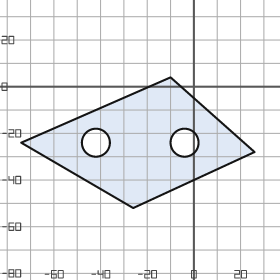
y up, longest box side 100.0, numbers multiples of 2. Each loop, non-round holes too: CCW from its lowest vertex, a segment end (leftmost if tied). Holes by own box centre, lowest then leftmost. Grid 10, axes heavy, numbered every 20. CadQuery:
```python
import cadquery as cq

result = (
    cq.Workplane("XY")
    .moveTo(-26.0, -52.0)
    .lineTo(26.0, -28.0)
    .lineTo(-10.0, 4.0)
    .lineTo(-74.0, -24.0)
    .close()
    .moveTo(-42.0, -24.0)
    .circle(6.0)
    .moveTo(-4.0, -24.0)
    .circle(6.0)
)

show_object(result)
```